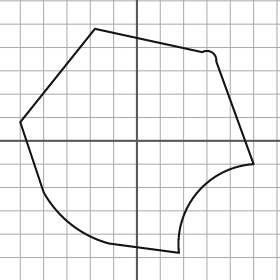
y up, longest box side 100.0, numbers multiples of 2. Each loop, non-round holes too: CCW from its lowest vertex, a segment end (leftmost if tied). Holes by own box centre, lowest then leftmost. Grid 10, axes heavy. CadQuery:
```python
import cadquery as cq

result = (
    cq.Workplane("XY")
    .moveTo(18.0, -48.0)
    .threePointArc((26.0, -22.0), (50.0, -10.0))
    .lineTo(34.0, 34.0)
    .threePointArc((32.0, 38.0), (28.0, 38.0))
    .lineTo(-18.0, 48.0)
    .lineTo(-50.0, 8.0)
    .lineTo(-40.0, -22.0)
    .threePointArc((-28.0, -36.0), (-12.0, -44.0))
    .close()
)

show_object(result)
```